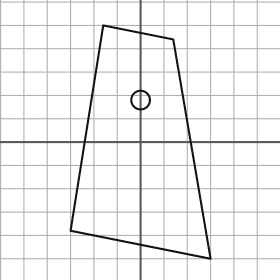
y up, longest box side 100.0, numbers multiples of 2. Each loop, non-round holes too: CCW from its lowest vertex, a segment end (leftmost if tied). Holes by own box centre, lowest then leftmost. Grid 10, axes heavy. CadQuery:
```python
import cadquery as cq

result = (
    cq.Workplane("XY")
    .moveTo(30.0, -50.0)
    .lineTo(14.0, 44.0)
    .lineTo(-16.0, 50.0)
    .lineTo(-30.0, -38.0)
    .close()
    .moveTo(0.0, 18.0)
    .circle(4.0)
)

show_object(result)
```